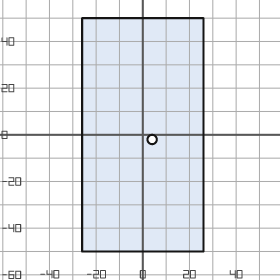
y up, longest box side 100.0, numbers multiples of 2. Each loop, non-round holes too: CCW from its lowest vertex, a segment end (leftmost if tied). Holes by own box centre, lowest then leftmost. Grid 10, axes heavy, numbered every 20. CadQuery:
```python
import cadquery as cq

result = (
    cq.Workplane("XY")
    .moveTo(-26.0, -50.0)
    .lineTo(26.0, -50.0)
    .lineTo(26.0, 50.0)
    .lineTo(-26.0, 50.0)
    .close()
    .moveTo(4.0, -2.0)
    .circle(2.0)
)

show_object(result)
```